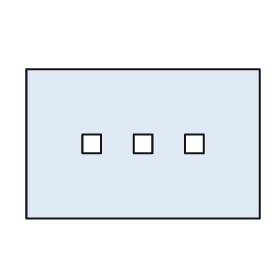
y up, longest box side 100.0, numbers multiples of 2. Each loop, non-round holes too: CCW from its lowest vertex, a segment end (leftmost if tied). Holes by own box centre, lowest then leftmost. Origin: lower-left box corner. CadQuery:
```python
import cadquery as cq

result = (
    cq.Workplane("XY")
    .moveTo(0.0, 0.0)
    .lineTo(100.0, 0.0)
    .lineTo(100.0, 64.0)
    .lineTo(0.0, 64.0)
    .close()
    .moveTo(24.0, 28.0)
    .lineTo(32.0, 28.0)
    .lineTo(32.0, 36.0)
    .lineTo(24.0, 36.0)
    .close()
    .moveTo(46.0, 28.0)
    .lineTo(54.0, 28.0)
    .lineTo(54.0, 36.0)
    .lineTo(46.0, 36.0)
    .close()
    .moveTo(68.0, 28.0)
    .lineTo(76.0, 28.0)
    .lineTo(76.0, 36.0)
    .lineTo(68.0, 36.0)
    .close()
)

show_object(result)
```